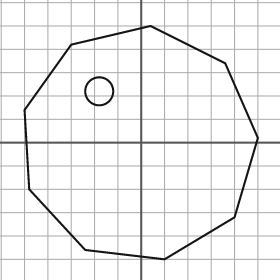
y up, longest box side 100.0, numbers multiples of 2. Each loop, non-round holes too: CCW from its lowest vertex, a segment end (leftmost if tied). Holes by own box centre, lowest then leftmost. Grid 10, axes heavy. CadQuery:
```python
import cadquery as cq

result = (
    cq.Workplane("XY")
    .moveTo(10.0, -50.0)
    .lineTo(40.0, -32.0)
    .lineTo(50.0, 2.0)
    .lineTo(36.0, 34.0)
    .lineTo(4.0, 50.0)
    .lineTo(-30.0, 42.0)
    .lineTo(-50.0, 14.0)
    .lineTo(-48.0, -20.0)
    .lineTo(-24.0, -46.0)
    .close()
    .moveTo(-18.0, 22.0)
    .circle(6.0)
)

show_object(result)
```